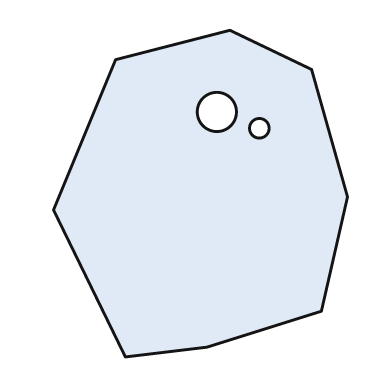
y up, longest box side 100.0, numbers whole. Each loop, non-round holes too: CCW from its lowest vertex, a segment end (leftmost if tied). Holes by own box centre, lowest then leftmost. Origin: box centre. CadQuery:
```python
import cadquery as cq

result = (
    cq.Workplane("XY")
    .moveTo(-23.0, -50.0)
    .lineTo(2.0, -47.0)
    .lineTo(37.0, -36.0)
    .lineTo(45.0, -1.0)
    .lineTo(34.0, 38.0)
    .lineTo(9.0, 50.0)
    .lineTo(-26.0, 41.0)
    .lineTo(-45.0, -5.0)
    .close()
    .moveTo(18.0, 20.0)
    .circle(3.0)
    .moveTo(5.0, 25.0)
    .circle(6.0)
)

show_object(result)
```